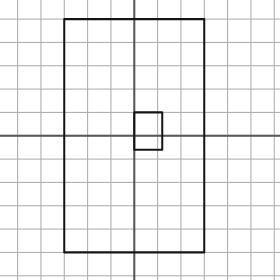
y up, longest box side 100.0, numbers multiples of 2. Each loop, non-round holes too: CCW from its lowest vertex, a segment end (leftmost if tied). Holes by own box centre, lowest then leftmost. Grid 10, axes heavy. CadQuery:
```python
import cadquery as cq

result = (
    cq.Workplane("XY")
    .moveTo(-30.0, -50.0)
    .lineTo(30.0, -50.0)
    .lineTo(30.0, 50.0)
    .lineTo(-30.0, 50.0)
    .close()
    .moveTo(0.0, -6.0)
    .lineTo(12.0, -6.0)
    .lineTo(12.0, 10.0)
    .lineTo(0.0, 10.0)
    .close()
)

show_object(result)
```